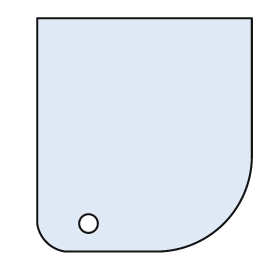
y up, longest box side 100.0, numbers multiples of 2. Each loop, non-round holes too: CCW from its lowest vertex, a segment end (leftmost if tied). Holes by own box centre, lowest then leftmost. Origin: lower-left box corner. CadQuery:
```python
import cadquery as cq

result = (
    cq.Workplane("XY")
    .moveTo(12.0, 0.0)
    .lineTo(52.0, 0.0)
    .threePointArc((80.0, 12.0), (92.0, 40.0))
    .lineTo(92.0, 100.0)
    .lineTo(0.0, 100.0)
    .lineTo(0.0, 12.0)
    .threePointArc((4.0, 4.0), (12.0, 0.0))
    .close()
    .moveTo(22.0, 12.0)
    .circle(4.0)
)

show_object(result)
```